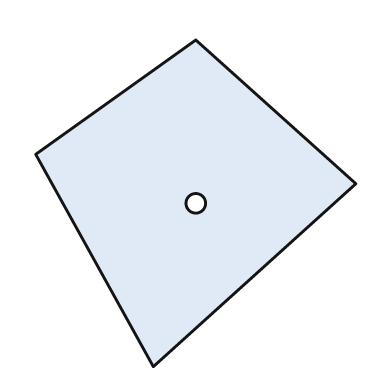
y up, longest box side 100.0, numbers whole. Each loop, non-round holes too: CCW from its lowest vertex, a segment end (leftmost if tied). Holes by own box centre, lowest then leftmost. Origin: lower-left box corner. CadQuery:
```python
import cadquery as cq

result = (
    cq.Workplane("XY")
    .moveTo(36.0, 0.0)
    .lineTo(98.0, 56.0)
    .lineTo(49.0, 100.0)
    .lineTo(0.0, 65.0)
    .close()
    .moveTo(49.0, 50.0)
    .circle(3.0)
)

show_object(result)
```